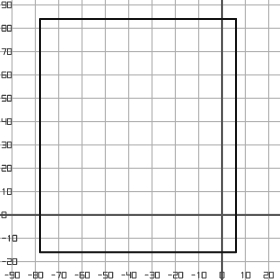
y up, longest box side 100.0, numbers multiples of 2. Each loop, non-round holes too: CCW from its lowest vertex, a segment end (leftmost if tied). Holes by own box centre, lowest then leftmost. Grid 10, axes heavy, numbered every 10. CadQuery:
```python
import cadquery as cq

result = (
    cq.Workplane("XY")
    .moveTo(-78.0, -16.0)
    .lineTo(6.0, -16.0)
    .lineTo(6.0, 84.0)
    .lineTo(-78.0, 84.0)
    .close()
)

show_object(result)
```